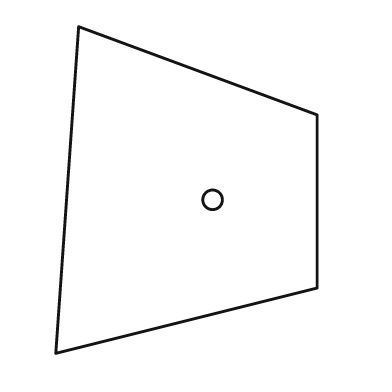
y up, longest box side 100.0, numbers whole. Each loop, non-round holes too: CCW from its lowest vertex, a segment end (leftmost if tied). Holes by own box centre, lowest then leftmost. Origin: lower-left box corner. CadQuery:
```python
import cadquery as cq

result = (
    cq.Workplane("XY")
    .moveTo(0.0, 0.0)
    .lineTo(80.0, 20.0)
    .lineTo(80.0, 73.0)
    .lineTo(7.0, 100.0)
    .close()
    .moveTo(48.0, 47.0)
    .circle(3.0)
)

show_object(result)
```